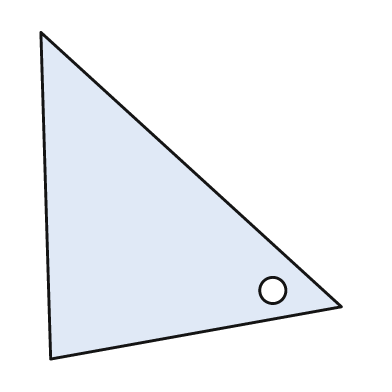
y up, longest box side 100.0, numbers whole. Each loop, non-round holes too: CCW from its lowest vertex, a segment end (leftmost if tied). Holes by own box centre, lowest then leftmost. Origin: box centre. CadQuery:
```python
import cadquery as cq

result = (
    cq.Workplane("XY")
    .moveTo(-43.0, -50.0)
    .lineTo(46.0, -34.0)
    .lineTo(-46.0, 50.0)
    .close()
    .moveTo(25.0, -29.0)
    .circle(4.0)
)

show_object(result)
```